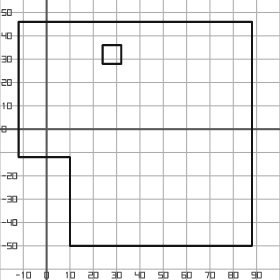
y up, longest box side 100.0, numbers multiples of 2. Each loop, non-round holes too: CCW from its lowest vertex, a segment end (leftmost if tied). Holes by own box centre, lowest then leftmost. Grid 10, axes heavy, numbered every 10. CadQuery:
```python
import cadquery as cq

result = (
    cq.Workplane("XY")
    .moveTo(10.0, -50.0)
    .lineTo(88.0, -50.0)
    .lineTo(88.0, 46.0)
    .lineTo(-12.0, 46.0)
    .lineTo(-12.0, -12.0)
    .lineTo(10.0, -12.0)
    .close()
    .moveTo(24.0, 28.0)
    .lineTo(32.0, 28.0)
    .lineTo(32.0, 36.0)
    .lineTo(24.0, 36.0)
    .close()
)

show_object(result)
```